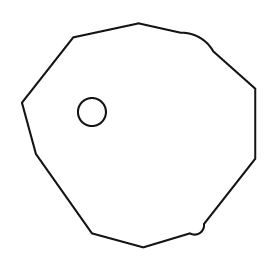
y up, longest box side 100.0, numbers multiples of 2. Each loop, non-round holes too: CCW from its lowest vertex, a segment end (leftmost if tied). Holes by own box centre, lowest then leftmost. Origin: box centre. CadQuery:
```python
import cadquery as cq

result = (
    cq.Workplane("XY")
    .moveTo(2.0, -48.0)
    .lineTo(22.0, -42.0)
    .threePointArc((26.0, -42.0), (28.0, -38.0))
    .lineTo(50.0, -10.0)
    .lineTo(50.0, 20.0)
    .lineTo(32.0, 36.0)
    .threePointArc((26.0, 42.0), (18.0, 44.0))
    .lineTo(0.0, 48.0)
    .lineTo(-28.0, 42.0)
    .lineTo(-50.0, 14.0)
    .lineTo(-44.0, -8.0)
    .lineTo(-20.0, -42.0)
    .close()
    .moveTo(-20.0, 10.0)
    .circle(6.0)
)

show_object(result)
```